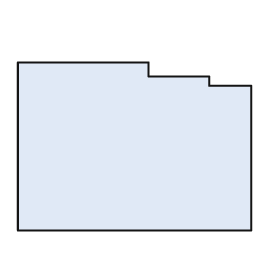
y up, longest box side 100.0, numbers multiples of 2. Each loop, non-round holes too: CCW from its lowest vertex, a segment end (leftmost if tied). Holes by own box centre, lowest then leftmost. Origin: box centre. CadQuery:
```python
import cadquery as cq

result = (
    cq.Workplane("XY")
    .moveTo(-50.0, -36.0)
    .lineTo(50.0, -36.0)
    .lineTo(50.0, 26.0)
    .lineTo(32.0, 26.0)
    .lineTo(32.0, 30.0)
    .lineTo(6.0, 30.0)
    .lineTo(6.0, 36.0)
    .lineTo(-50.0, 36.0)
    .close()
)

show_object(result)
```